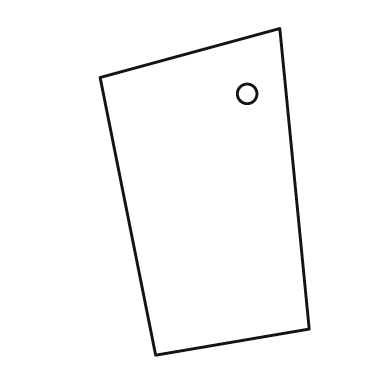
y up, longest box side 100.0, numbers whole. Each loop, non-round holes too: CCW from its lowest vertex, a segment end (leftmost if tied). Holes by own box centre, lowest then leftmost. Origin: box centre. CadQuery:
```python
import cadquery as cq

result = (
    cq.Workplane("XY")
    .moveTo(-15.0, -50.0)
    .lineTo(32.0, -42.0)
    .lineTo(23.0, 50.0)
    .lineTo(-32.0, 35.0)
    .close()
    .moveTo(13.0, 30.0)
    .circle(3.0)
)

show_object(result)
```